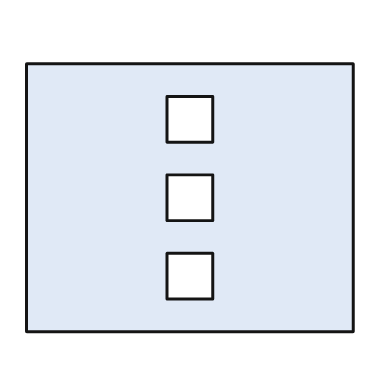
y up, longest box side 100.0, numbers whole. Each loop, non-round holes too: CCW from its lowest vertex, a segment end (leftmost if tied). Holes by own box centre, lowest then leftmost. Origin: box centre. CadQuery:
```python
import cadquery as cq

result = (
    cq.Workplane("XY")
    .moveTo(-50.0, -41.0)
    .lineTo(50.0, -41.0)
    .lineTo(50.0, 41.0)
    .lineTo(-50.0, 41.0)
    .close()
    .moveTo(-7.0, -31.0)
    .lineTo(7.0, -31.0)
    .lineTo(7.0, -17.0)
    .lineTo(-7.0, -17.0)
    .close()
    .moveTo(-7.0, -7.0)
    .lineTo(7.0, -7.0)
    .lineTo(7.0, 7.0)
    .lineTo(-7.0, 7.0)
    .close()
    .moveTo(-7.0, 17.0)
    .lineTo(7.0, 17.0)
    .lineTo(7.0, 31.0)
    .lineTo(-7.0, 31.0)
    .close()
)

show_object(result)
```